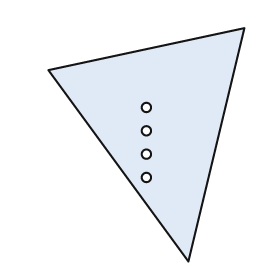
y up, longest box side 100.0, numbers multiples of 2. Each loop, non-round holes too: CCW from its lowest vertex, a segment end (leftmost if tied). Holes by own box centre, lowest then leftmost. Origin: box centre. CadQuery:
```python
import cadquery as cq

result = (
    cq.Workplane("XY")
    .moveTo(18.0, -50.0)
    .lineTo(42.0, 50.0)
    .lineTo(-42.0, 32.0)
    .close()
    .moveTo(0.0, -14.0)
    .circle(2.0)
    .moveTo(0.0, -4.0)
    .circle(2.0)
    .moveTo(0.0, 6.0)
    .circle(2.0)
    .moveTo(0.0, 16.0)
    .circle(2.0)
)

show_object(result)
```